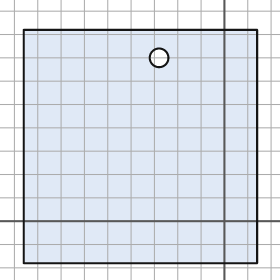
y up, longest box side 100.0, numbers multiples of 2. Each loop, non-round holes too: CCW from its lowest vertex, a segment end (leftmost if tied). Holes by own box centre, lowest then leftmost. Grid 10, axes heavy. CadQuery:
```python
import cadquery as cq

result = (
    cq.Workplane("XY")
    .moveTo(-86.0, -18.0)
    .lineTo(14.0, -18.0)
    .lineTo(14.0, 82.0)
    .lineTo(-86.0, 82.0)
    .close()
    .moveTo(-28.0, 70.0)
    .circle(4.0)
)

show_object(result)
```